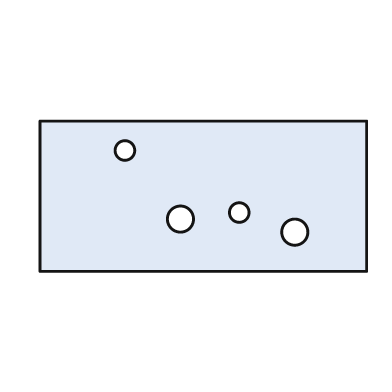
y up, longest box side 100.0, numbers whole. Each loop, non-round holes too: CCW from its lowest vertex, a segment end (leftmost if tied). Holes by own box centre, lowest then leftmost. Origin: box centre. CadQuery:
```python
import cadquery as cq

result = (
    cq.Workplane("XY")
    .moveTo(-50.0, -23.0)
    .lineTo(50.0, -23.0)
    .lineTo(50.0, 23.0)
    .lineTo(-50.0, 23.0)
    .close()
    .moveTo(28.0, -11.0)
    .circle(4.0)
    .moveTo(-7.0, -7.0)
    .circle(4.0)
    .moveTo(11.0, -5.0)
    .circle(3.0)
    .moveTo(-24.0, 14.0)
    .circle(3.0)
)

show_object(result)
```